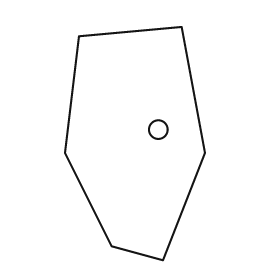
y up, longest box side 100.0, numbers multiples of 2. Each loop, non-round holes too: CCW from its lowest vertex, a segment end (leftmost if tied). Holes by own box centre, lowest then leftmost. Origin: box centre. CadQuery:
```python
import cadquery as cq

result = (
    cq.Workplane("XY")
    .moveTo(12.0, -50.0)
    .lineTo(30.0, -4.0)
    .lineTo(20.0, 50.0)
    .lineTo(-24.0, 46.0)
    .lineTo(-30.0, -4.0)
    .lineTo(-10.0, -44.0)
    .close()
    .moveTo(10.0, 6.0)
    .circle(4.0)
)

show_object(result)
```